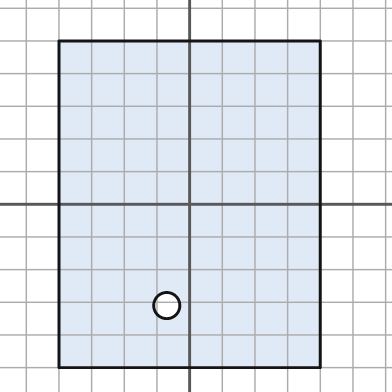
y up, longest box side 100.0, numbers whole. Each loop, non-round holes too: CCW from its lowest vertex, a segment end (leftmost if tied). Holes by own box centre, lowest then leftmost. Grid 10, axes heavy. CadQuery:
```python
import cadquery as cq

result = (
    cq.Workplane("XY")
    .moveTo(-40.0, -50.0)
    .lineTo(40.0, -50.0)
    .lineTo(40.0, 50.0)
    .lineTo(-40.0, 50.0)
    .close()
    .moveTo(-7.0, -31.0)
    .circle(4.0)
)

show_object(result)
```